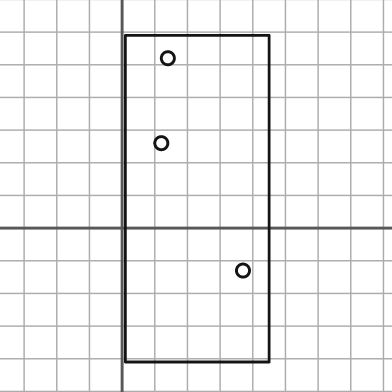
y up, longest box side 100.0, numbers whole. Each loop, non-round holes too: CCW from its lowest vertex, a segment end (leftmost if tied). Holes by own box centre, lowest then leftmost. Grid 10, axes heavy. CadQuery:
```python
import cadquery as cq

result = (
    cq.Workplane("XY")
    .moveTo(1.0, -41.0)
    .lineTo(45.0, -41.0)
    .lineTo(45.0, 59.0)
    .lineTo(1.0, 59.0)
    .close()
    .moveTo(37.0, -13.0)
    .circle(2.0)
    .moveTo(12.0, 26.0)
    .circle(2.0)
    .moveTo(14.0, 52.0)
    .circle(2.0)
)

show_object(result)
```